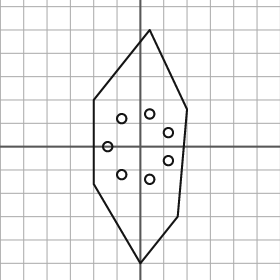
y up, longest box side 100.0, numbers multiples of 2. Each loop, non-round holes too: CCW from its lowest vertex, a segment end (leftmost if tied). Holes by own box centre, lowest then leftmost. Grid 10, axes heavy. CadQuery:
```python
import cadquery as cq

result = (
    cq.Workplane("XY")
    .moveTo(0.0, -50.0)
    .lineTo(16.0, -30.0)
    .lineTo(20.0, 16.0)
    .lineTo(4.0, 50.0)
    .lineTo(-20.0, 20.0)
    .lineTo(-20.0, -16.0)
    .close()
    .moveTo(4.0, -14.0)
    .circle(2.0)
    .moveTo(-8.0, -12.0)
    .circle(2.0)
    .moveTo(12.0, -6.0)
    .circle(2.0)
    .moveTo(-14.0, 0.0)
    .circle(2.0)
    .moveTo(12.0, 6.0)
    .circle(2.0)
    .moveTo(-8.0, 12.0)
    .circle(2.0)
    .moveTo(4.0, 14.0)
    .circle(2.0)
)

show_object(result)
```